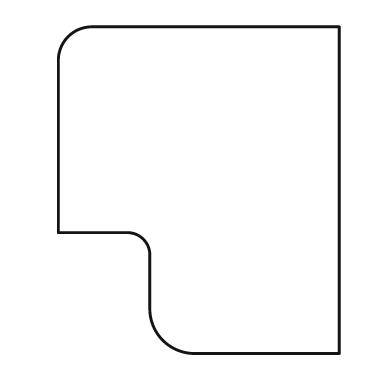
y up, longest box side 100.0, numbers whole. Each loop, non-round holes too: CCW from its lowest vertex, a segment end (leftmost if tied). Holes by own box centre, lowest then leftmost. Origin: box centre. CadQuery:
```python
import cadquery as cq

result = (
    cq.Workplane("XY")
    .moveTo(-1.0, -50.0)
    .lineTo(43.0, -50.0)
    .lineTo(43.0, 50.0)
    .lineTo(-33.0, 50.0)
    .threePointArc((-40.0, 47.0), (-43.0, 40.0))
    .lineTo(-43.0, -13.0)
    .lineTo(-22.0, -13.0)
    .threePointArc((-17.0, -15.0), (-15.0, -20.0))
    .lineTo(-15.0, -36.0)
    .threePointArc((-11.0, -46.0), (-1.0, -50.0))
    .close()
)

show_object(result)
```